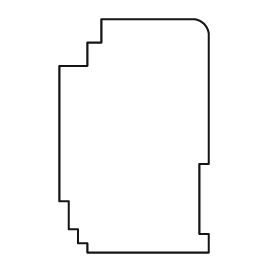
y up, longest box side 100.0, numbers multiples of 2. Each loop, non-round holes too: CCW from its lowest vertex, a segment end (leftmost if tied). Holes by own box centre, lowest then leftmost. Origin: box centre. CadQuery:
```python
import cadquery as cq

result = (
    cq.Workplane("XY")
    .moveTo(-20.0, -50.0)
    .lineTo(32.0, -50.0)
    .lineTo(32.0, -42.0)
    .lineTo(28.0, -42.0)
    .lineTo(28.0, -12.0)
    .lineTo(32.0, -12.0)
    .lineTo(32.0, 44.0)
    .threePointArc((30.0, 48.0), (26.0, 50.0))
    .lineTo(-14.0, 50.0)
    .lineTo(-14.0, 40.0)
    .lineTo(-20.0, 40.0)
    .lineTo(-20.0, 30.0)
    .lineTo(-32.0, 30.0)
    .lineTo(-32.0, -28.0)
    .lineTo(-28.0, -28.0)
    .lineTo(-28.0, -40.0)
    .lineTo(-24.0, -40.0)
    .lineTo(-24.0, -46.0)
    .lineTo(-20.0, -46.0)
    .close()
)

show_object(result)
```